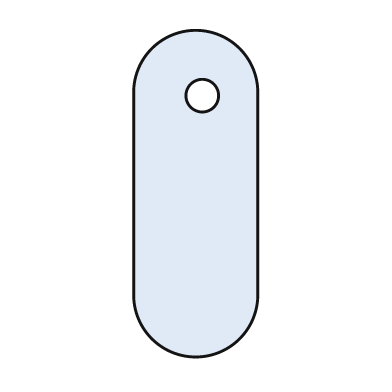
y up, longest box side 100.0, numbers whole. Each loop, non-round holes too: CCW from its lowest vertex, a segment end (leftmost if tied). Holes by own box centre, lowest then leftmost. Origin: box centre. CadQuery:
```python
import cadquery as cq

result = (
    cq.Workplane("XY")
    .moveTo(-19.0, -31.0)
    .threePointArc((0.0, -50.0), (19.0, -31.0))
    .lineTo(19.0, 31.0)
    .threePointArc((0.0, 50.0), (-19.0, 31.0))
    .close()
    .moveTo(2.0, 30.0)
    .circle(5.0)
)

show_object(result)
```